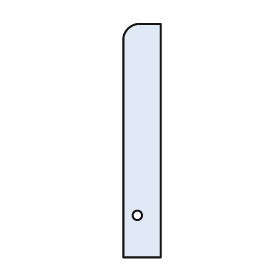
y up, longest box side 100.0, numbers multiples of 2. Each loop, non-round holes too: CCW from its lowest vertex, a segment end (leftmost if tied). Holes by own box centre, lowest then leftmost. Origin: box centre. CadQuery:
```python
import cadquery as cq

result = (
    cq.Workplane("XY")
    .moveTo(-8.0, -50.0)
    .lineTo(8.0, -50.0)
    .lineTo(8.0, 50.0)
    .lineTo(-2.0, 50.0)
    .threePointArc((-6.0, 48.0), (-8.0, 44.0))
    .close()
    .moveTo(-2.0, -32.0)
    .circle(2.0)
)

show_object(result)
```